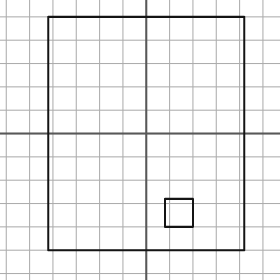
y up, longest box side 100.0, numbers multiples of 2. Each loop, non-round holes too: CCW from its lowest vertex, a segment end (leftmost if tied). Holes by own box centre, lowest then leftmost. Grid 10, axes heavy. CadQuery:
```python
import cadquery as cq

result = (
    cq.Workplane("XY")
    .moveTo(-42.0, -50.0)
    .lineTo(42.0, -50.0)
    .lineTo(42.0, 50.0)
    .lineTo(-42.0, 50.0)
    .close()
    .moveTo(8.0, -40.0)
    .lineTo(20.0, -40.0)
    .lineTo(20.0, -28.0)
    .lineTo(8.0, -28.0)
    .close()
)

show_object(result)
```